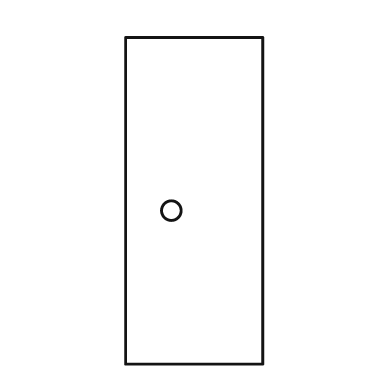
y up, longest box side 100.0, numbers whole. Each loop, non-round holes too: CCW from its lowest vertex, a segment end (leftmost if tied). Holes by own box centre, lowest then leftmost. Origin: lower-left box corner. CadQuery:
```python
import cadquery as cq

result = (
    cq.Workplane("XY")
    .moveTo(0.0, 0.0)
    .lineTo(42.0, 0.0)
    .lineTo(42.0, 100.0)
    .lineTo(0.0, 100.0)
    .close()
    .moveTo(14.0, 47.0)
    .circle(3.0)
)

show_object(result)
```